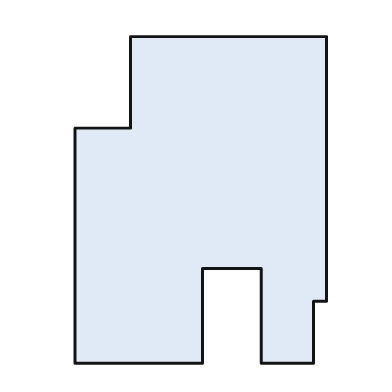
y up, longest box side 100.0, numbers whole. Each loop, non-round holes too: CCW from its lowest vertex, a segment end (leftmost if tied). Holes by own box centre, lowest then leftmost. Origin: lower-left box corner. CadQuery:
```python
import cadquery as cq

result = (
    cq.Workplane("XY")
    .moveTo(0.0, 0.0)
    .lineTo(39.0, 0.0)
    .lineTo(39.0, 29.0)
    .lineTo(57.0, 29.0)
    .lineTo(57.0, 0.0)
    .lineTo(73.0, 0.0)
    .lineTo(73.0, 19.0)
    .lineTo(77.0, 19.0)
    .lineTo(77.0, 100.0)
    .lineTo(17.0, 100.0)
    .lineTo(17.0, 72.0)
    .lineTo(0.0, 72.0)
    .close()
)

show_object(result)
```